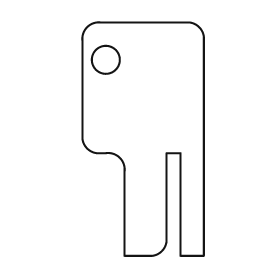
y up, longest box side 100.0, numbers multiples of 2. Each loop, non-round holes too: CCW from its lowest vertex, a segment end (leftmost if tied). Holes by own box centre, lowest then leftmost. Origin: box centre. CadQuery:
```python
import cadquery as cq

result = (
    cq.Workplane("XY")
    .moveTo(-8.0, -50.0)
    .lineTo(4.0, -50.0)
    .threePointArc((8.0, -48.0), (10.0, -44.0))
    .lineTo(10.0, -6.0)
    .lineTo(16.0, -6.0)
    .lineTo(16.0, -50.0)
    .lineTo(26.0, -50.0)
    .lineTo(26.0, 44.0)
    .threePointArc((24.0, 48.0), (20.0, 50.0))
    .lineTo(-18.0, 50.0)
    .threePointArc((-24.0, 48.0), (-26.0, 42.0))
    .lineTo(-26.0, 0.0)
    .threePointArc((-24.0, -4.0), (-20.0, -6.0))
    .lineTo(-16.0, -6.0)
    .threePointArc((-10.0, -8.0), (-8.0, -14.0))
    .close()
    .moveTo(-16.0, 34.0)
    .circle(6.0)
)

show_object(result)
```